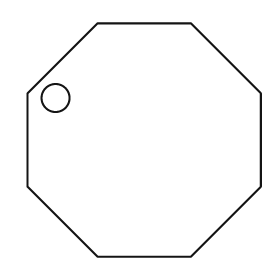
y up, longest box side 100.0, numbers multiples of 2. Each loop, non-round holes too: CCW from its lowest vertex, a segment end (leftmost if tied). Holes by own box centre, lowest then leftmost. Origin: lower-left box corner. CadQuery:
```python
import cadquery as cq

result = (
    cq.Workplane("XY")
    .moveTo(30.0, 0.0)
    .lineTo(70.0, 0.0)
    .lineTo(100.0, 30.0)
    .lineTo(100.0, 70.0)
    .lineTo(70.0, 100.0)
    .lineTo(30.0, 100.0)
    .lineTo(0.0, 70.0)
    .lineTo(0.0, 30.0)
    .close()
    .moveTo(12.0, 68.0)
    .circle(6.0)
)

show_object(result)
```